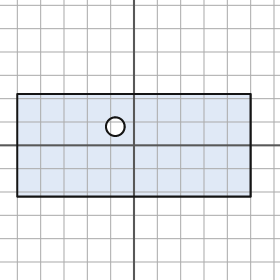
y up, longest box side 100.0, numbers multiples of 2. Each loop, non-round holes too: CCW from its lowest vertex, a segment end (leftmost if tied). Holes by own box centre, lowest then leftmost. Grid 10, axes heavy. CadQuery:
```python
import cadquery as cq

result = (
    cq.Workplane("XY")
    .moveTo(-50.0, -22.0)
    .lineTo(50.0, -22.0)
    .lineTo(50.0, 22.0)
    .lineTo(-50.0, 22.0)
    .close()
    .moveTo(-8.0, 8.0)
    .circle(4.0)
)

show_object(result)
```